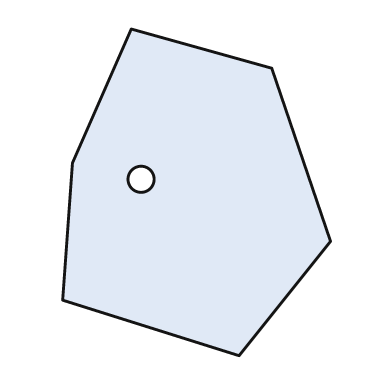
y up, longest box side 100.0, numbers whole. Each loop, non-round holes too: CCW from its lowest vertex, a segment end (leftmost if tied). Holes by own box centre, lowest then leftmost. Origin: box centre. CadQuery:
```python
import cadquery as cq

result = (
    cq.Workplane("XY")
    .moveTo(13.0, -50.0)
    .lineTo(41.0, -15.0)
    .lineTo(23.0, 38.0)
    .lineTo(-20.0, 50.0)
    .lineTo(-38.0, 9.0)
    .lineTo(-41.0, -33.0)
    .close()
    .moveTo(-17.0, 4.0)
    .circle(4.0)
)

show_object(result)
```